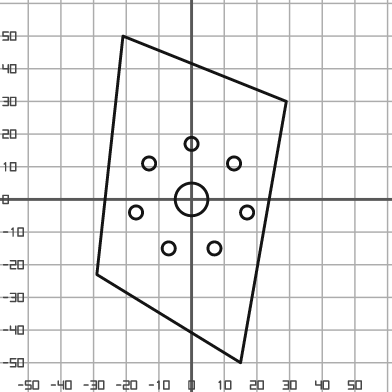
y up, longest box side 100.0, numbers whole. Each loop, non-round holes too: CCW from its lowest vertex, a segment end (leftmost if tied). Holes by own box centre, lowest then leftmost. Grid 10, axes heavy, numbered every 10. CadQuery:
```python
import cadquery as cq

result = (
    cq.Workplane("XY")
    .moveTo(15.0, -50.0)
    .lineTo(29.0, 30.0)
    .lineTo(-21.0, 50.0)
    .lineTo(-29.0, -23.0)
    .close()
    .moveTo(-7.0, -15.0)
    .circle(2.0)
    .moveTo(7.0, -15.0)
    .circle(2.0)
    .moveTo(-17.0, -4.0)
    .circle(2.0)
    .moveTo(17.0, -4.0)
    .circle(2.0)
    .moveTo(0.0, 0.0)
    .circle(5.0)
    .moveTo(-13.0, 11.0)
    .circle(2.0)
    .moveTo(13.0, 11.0)
    .circle(2.0)
    .moveTo(0.0, 17.0)
    .circle(2.0)
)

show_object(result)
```